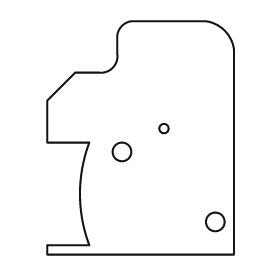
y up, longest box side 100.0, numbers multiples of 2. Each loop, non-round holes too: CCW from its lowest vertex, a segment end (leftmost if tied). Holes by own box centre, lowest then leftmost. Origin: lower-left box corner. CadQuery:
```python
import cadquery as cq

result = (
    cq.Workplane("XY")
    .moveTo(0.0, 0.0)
    .lineTo(80.0, 0.0)
    .lineTo(80.0, 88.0)
    .threePointArc((76.0, 96.0), (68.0, 100.0))
    .lineTo(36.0, 100.0)
    .threePointArc((32.0, 98.0), (30.0, 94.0))
    .lineTo(30.0, 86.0)
    .threePointArc((28.0, 80.0), (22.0, 78.0))
    .lineTo(12.0, 78.0)
    .lineTo(0.0, 66.0)
    .lineTo(0.0, 48.0)
    .lineTo(18.0, 48.0)
    .threePointArc((14.0, 26.0), (18.0, 4.0))
    .lineTo(0.0, 4.0)
    .close()
    .moveTo(72.0, 14.0)
    .circle(4.0)
    .moveTo(32.0, 44.0)
    .circle(4.0)
    .moveTo(50.0, 54.0)
    .circle(2.0)
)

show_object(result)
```